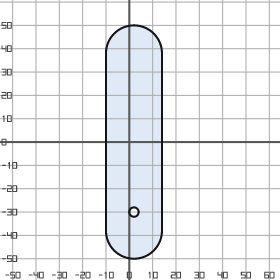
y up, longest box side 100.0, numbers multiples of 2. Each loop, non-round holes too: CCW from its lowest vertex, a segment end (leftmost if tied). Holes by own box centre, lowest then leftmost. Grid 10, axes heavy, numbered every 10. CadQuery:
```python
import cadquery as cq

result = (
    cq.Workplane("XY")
    .moveTo(-10.0, -38.0)
    .threePointArc((2.0, -50.0), (14.0, -38.0))
    .lineTo(14.0, 38.0)
    .threePointArc((2.0, 50.0), (-10.0, 38.0))
    .close()
    .moveTo(2.0, -30.0)
    .circle(2.0)
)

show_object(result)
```